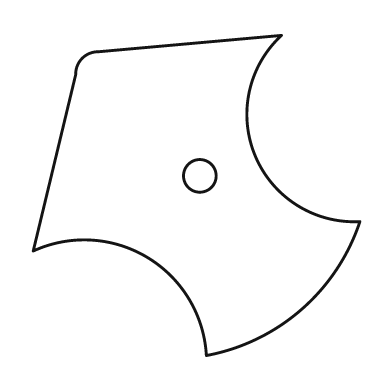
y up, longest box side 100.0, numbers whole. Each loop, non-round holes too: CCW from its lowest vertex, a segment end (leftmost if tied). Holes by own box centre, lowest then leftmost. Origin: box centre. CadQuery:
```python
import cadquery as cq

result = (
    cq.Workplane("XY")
    .moveTo(3.0, -49.0)
    .threePointArc((32.0, -35.0), (50.0, -8.0))
    .threePointArc((18.0, 12.0), (26.0, 49.0))
    .lineTo(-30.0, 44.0)
    .threePointArc((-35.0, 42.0), (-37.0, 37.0))
    .lineTo(-50.0, -17.0)
    .threePointArc((-15.0, -19.0), (3.0, -49.0))
    .close()
    .moveTo(1.0, 6.0)
    .circle(5.0)
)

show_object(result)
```